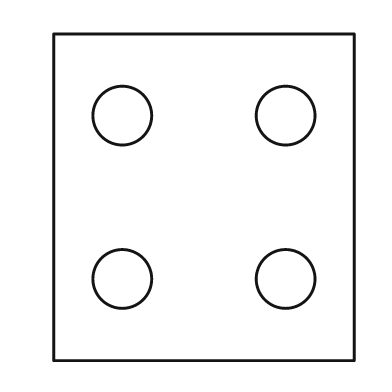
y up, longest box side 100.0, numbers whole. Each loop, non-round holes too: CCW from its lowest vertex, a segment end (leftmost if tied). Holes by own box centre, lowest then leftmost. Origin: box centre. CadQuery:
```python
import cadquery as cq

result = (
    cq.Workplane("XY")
    .moveTo(-46.0, -50.0)
    .lineTo(46.0, -50.0)
    .lineTo(46.0, 50.0)
    .lineTo(-46.0, 50.0)
    .close()
    .moveTo(-25.0, -25.0)
    .circle(9.0)
    .moveTo(25.0, -25.0)
    .circle(9.0)
    .moveTo(-25.0, 25.0)
    .circle(9.0)
    .moveTo(25.0, 25.0)
    .circle(9.0)
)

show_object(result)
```